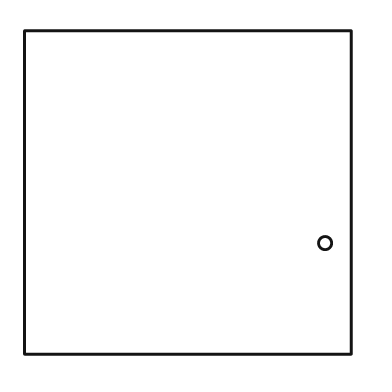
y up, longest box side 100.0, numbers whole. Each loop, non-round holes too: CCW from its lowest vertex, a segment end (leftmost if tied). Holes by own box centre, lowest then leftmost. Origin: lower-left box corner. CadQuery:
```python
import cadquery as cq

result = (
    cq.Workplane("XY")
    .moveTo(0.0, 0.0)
    .lineTo(100.0, 0.0)
    .lineTo(100.0, 99.0)
    .lineTo(0.0, 99.0)
    .close()
    .moveTo(92.0, 34.0)
    .circle(2.0)
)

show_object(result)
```